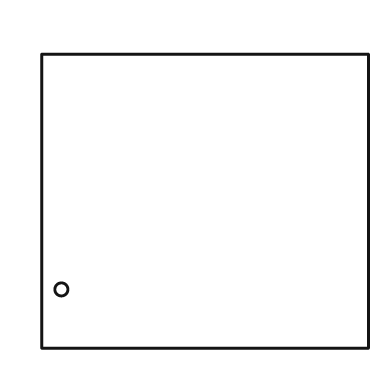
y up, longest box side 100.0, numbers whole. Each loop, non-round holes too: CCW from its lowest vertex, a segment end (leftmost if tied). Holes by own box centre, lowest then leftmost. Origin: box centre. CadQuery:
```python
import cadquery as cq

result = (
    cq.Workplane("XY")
    .moveTo(-50.0, -45.0)
    .lineTo(50.0, -45.0)
    .lineTo(50.0, 45.0)
    .lineTo(-50.0, 45.0)
    .close()
    .moveTo(-44.0, -27.0)
    .circle(2.0)
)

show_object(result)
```